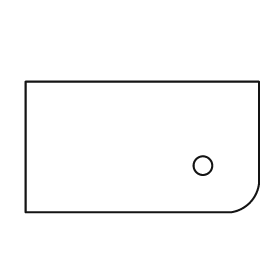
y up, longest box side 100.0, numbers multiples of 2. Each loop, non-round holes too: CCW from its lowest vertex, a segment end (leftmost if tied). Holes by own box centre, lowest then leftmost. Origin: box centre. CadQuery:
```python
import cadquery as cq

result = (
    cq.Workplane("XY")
    .moveTo(-50.0, -28.0)
    .lineTo(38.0, -28.0)
    .threePointArc((46.0, -24.0), (50.0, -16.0))
    .lineTo(50.0, 28.0)
    .lineTo(-50.0, 28.0)
    .close()
    .moveTo(26.0, -8.0)
    .circle(4.0)
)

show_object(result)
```